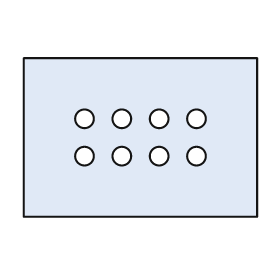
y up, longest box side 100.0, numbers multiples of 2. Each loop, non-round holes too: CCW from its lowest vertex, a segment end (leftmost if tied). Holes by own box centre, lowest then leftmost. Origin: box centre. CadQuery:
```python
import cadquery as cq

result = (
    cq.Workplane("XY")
    .moveTo(-50.0, -34.0)
    .lineTo(50.0, -34.0)
    .lineTo(50.0, 34.0)
    .lineTo(-50.0, 34.0)
    .close()
    .moveTo(-24.0, -8.0)
    .circle(4.0)
    .moveTo(-8.0, -8.0)
    .circle(4.0)
    .moveTo(8.0, -8.0)
    .circle(4.0)
    .moveTo(24.0, -8.0)
    .circle(4.0)
    .moveTo(-24.0, 8.0)
    .circle(4.0)
    .moveTo(-8.0, 8.0)
    .circle(4.0)
    .moveTo(8.0, 8.0)
    .circle(4.0)
    .moveTo(24.0, 8.0)
    .circle(4.0)
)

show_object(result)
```